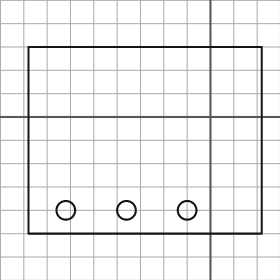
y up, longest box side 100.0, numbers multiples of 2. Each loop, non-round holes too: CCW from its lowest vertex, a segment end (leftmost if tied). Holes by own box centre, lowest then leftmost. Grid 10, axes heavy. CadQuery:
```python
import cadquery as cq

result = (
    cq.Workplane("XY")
    .moveTo(-78.0, -50.0)
    .lineTo(22.0, -50.0)
    .lineTo(22.0, 30.0)
    .lineTo(-78.0, 30.0)
    .close()
    .moveTo(-62.0, -40.0)
    .circle(4.0)
    .moveTo(-36.0, -40.0)
    .circle(4.0)
    .moveTo(-10.0, -40.0)
    .circle(4.0)
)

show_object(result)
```